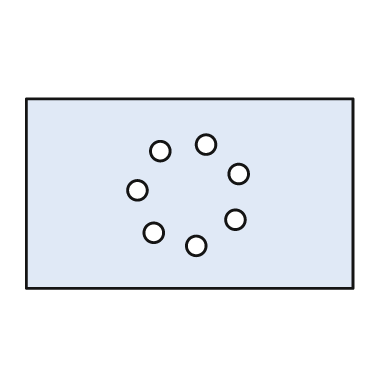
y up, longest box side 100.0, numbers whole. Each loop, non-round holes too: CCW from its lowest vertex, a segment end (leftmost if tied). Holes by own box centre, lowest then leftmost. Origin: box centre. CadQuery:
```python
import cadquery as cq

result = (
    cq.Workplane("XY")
    .moveTo(-50.0, -29.0)
    .lineTo(50.0, -29.0)
    .lineTo(50.0, 29.0)
    .lineTo(-50.0, 29.0)
    .close()
    .moveTo(2.0, -16.0)
    .circle(3.0)
    .moveTo(-11.0, -12.0)
    .circle(3.0)
    .moveTo(14.0, -8.0)
    .circle(3.0)
    .moveTo(-16.0, 1.0)
    .circle(3.0)
    .moveTo(15.0, 6.0)
    .circle(3.0)
    .moveTo(-9.0, 13.0)
    .circle(3.0)
    .moveTo(5.0, 15.0)
    .circle(3.0)
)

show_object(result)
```